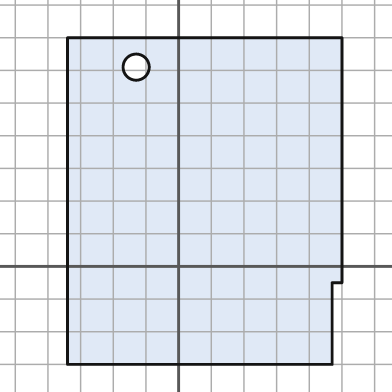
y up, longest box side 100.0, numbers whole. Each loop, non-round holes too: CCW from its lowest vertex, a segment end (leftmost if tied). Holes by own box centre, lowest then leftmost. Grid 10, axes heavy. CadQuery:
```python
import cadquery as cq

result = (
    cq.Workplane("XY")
    .moveTo(-34.0, -30.0)
    .lineTo(47.0, -30.0)
    .lineTo(47.0, -5.0)
    .lineTo(50.0, -5.0)
    .lineTo(50.0, 70.0)
    .lineTo(-34.0, 70.0)
    .close()
    .moveTo(-13.0, 61.0)
    .circle(4.0)
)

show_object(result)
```